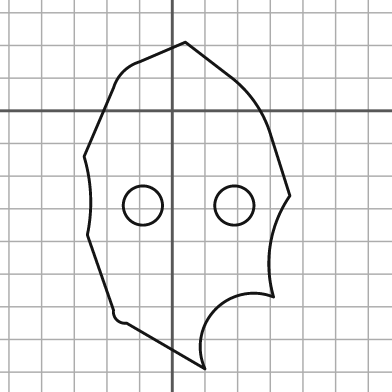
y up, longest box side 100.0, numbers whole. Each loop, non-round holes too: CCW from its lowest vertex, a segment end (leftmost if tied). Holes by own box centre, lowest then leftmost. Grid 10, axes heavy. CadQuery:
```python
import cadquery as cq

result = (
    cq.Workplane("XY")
    .moveTo(10.0, -79.0)
    .threePointArc((13.0, -61.0), (31.0, -57.0))
    .threePointArc((30.0, -41.0), (36.0, -26.0))
    .lineTo(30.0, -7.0)
    .threePointArc((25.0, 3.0), (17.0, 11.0))
    .lineTo(4.0, 21.0)
    .lineTo(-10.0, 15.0)
    .threePointArc((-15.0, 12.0), (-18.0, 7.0))
    .lineTo(-27.0, -14.0)
    .threePointArc((-25.0, -26.0), (-26.0, -38.0))
    .lineTo(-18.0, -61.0)
    .threePointArc((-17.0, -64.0), (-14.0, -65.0))
    .close()
    .moveTo(-9.0, -29.0)
    .circle(6.0)
    .moveTo(19.0, -29.0)
    .circle(6.0)
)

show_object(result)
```